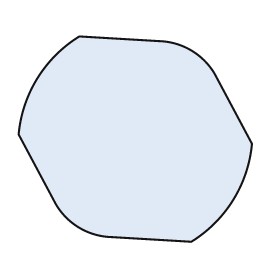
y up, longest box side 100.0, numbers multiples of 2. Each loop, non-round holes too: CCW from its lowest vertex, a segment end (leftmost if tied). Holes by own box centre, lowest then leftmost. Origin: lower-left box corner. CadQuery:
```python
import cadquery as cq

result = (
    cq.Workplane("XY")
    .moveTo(74.0, 0.0)
    .threePointArc((92.0, 18.0), (100.0, 42.0))
    .lineTo(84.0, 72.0)
    .threePointArc((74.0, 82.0), (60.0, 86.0))
    .lineTo(26.0, 88.0)
    .threePointArc((8.0, 70.0), (0.0, 46.0))
    .lineTo(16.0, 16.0)
    .threePointArc((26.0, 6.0), (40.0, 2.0))
    .close()
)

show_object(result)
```